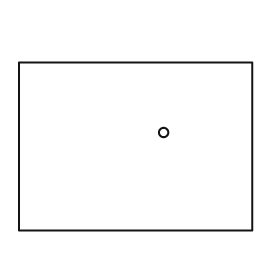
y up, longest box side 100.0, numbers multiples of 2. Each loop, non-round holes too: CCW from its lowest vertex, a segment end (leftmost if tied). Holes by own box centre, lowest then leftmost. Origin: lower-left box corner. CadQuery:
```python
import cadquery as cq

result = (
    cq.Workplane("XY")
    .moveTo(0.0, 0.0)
    .lineTo(100.0, 0.0)
    .lineTo(100.0, 72.0)
    .lineTo(0.0, 72.0)
    .close()
    .moveTo(62.0, 42.0)
    .circle(2.0)
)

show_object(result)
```